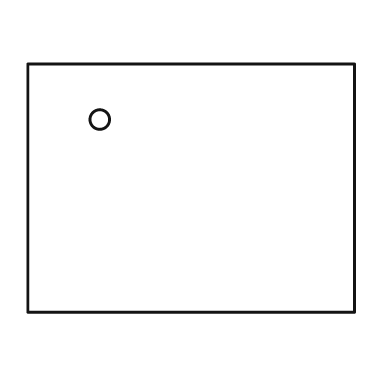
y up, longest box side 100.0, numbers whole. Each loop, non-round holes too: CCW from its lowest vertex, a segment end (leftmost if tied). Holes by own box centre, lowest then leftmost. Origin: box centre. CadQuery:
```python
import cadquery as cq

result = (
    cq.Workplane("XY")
    .moveTo(-50.0, -38.0)
    .lineTo(50.0, -38.0)
    .lineTo(50.0, 38.0)
    .lineTo(-50.0, 38.0)
    .close()
    .moveTo(-28.0, 21.0)
    .circle(3.0)
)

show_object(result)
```